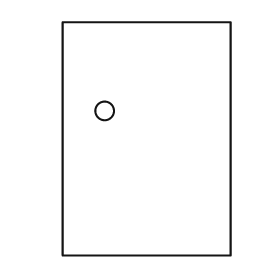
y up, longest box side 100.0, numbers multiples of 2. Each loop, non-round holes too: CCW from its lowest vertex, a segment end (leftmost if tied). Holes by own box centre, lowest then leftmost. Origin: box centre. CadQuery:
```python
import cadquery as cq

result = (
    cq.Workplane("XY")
    .moveTo(-36.0, -50.0)
    .lineTo(36.0, -50.0)
    .lineTo(36.0, 50.0)
    .lineTo(-36.0, 50.0)
    .close()
    .moveTo(-18.0, 12.0)
    .circle(4.0)
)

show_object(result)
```